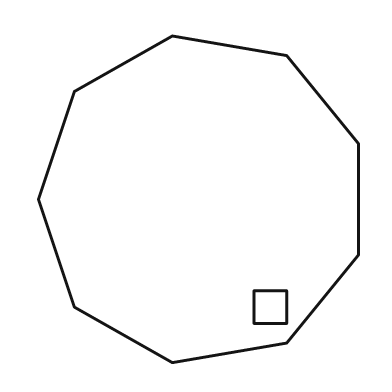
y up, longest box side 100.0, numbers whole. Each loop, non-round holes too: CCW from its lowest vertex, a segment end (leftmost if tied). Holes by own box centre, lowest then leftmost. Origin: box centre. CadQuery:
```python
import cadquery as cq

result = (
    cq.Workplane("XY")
    .moveTo(-8.0, -50.0)
    .lineTo(27.0, -44.0)
    .lineTo(49.0, -17.0)
    .lineTo(49.0, 17.0)
    .lineTo(27.0, 44.0)
    .lineTo(-8.0, 50.0)
    .lineTo(-38.0, 33.0)
    .lineTo(-49.0, 0.0)
    .lineTo(-38.0, -33.0)
    .close()
    .moveTo(17.0, -38.0)
    .lineTo(27.0, -38.0)
    .lineTo(27.0, -28.0)
    .lineTo(17.0, -28.0)
    .close()
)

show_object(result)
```